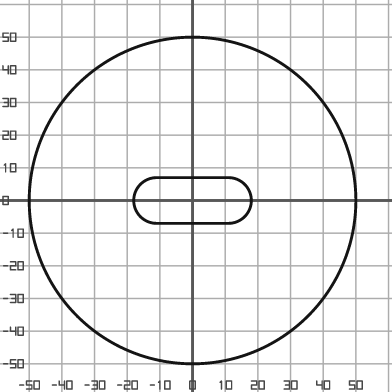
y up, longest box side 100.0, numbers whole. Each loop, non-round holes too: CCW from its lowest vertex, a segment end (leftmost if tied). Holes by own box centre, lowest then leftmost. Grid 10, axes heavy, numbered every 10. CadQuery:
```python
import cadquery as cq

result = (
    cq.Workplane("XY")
    .moveTo(0.0, 0.0)
    .circle(50.0)
    .moveTo(-11.0, -7.0)
    .lineTo(11.0, -7.0)
    .threePointArc((18.0, 0.0), (11.0, 7.0))
    .lineTo(-11.0, 7.0)
    .threePointArc((-18.0, 0.0), (-11.0, -7.0))
    .close()
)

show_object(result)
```